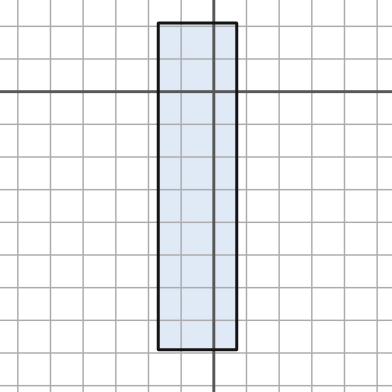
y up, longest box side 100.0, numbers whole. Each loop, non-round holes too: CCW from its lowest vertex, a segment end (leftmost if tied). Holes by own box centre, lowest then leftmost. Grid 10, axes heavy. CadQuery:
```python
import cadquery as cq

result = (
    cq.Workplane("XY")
    .moveTo(-17.0, -79.0)
    .lineTo(7.0, -79.0)
    .lineTo(7.0, 21.0)
    .lineTo(-17.0, 21.0)
    .close()
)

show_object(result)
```